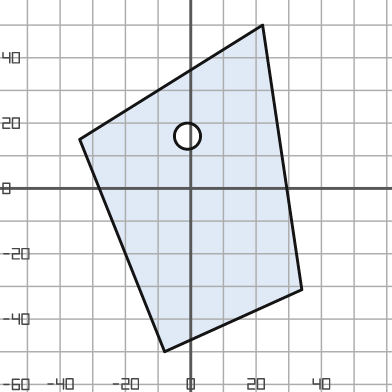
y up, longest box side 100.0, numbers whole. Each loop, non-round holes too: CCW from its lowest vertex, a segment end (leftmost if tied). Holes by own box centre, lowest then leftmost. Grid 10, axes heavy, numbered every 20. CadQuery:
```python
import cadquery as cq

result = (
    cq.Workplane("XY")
    .moveTo(-8.0, -50.0)
    .lineTo(34.0, -31.0)
    .lineTo(22.0, 50.0)
    .lineTo(-34.0, 15.0)
    .close()
    .moveTo(-1.0, 16.0)
    .circle(4.0)
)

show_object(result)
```